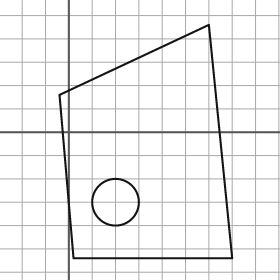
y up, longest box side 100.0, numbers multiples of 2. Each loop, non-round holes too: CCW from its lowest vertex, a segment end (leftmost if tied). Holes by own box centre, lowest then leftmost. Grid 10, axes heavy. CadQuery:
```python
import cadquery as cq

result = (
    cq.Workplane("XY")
    .moveTo(2.0, -54.0)
    .lineTo(70.0, -54.0)
    .lineTo(60.0, 46.0)
    .lineTo(-4.0, 16.0)
    .close()
    .moveTo(20.0, -30.0)
    .circle(10.0)
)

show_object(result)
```